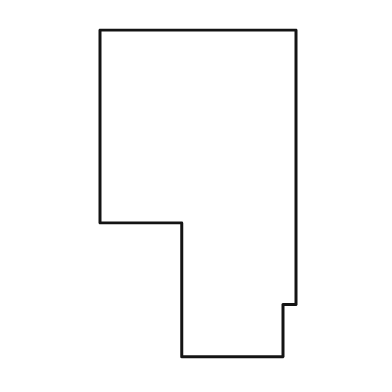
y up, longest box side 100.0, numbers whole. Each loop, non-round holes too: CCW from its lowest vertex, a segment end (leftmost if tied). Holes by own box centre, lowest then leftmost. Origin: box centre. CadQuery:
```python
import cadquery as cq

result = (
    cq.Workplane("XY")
    .moveTo(-5.0, -50.0)
    .lineTo(26.0, -50.0)
    .lineTo(26.0, -34.0)
    .lineTo(30.0, -34.0)
    .lineTo(30.0, 50.0)
    .lineTo(-30.0, 50.0)
    .lineTo(-30.0, -9.0)
    .lineTo(-5.0, -9.0)
    .close()
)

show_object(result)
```